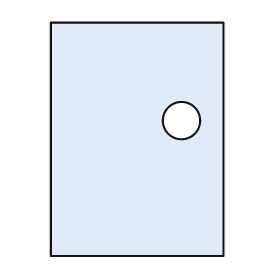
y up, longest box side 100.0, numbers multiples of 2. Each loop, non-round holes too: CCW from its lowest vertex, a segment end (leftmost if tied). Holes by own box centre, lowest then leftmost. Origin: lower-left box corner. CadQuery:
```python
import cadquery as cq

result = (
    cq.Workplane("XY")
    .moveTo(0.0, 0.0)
    .lineTo(74.0, 0.0)
    .lineTo(74.0, 100.0)
    .lineTo(0.0, 100.0)
    .close()
    .moveTo(56.0, 58.0)
    .circle(8.0)
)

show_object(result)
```